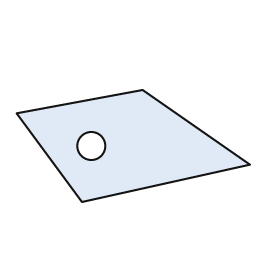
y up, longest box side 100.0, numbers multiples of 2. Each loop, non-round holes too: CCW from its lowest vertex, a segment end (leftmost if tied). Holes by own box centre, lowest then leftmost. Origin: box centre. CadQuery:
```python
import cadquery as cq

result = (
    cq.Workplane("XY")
    .moveTo(-22.0, -24.0)
    .lineTo(50.0, -8.0)
    .lineTo(4.0, 24.0)
    .lineTo(-50.0, 14.0)
    .close()
    .moveTo(-18.0, 0.0)
    .circle(6.0)
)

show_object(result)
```